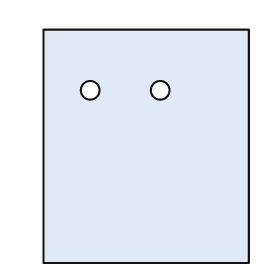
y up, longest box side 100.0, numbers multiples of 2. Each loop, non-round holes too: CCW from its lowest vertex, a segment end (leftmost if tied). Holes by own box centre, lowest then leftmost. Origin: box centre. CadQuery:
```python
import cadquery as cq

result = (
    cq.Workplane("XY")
    .moveTo(-44.0, -50.0)
    .lineTo(44.0, -50.0)
    .lineTo(44.0, 50.0)
    .lineTo(-44.0, 50.0)
    .close()
    .moveTo(-24.0, 24.0)
    .circle(4.0)
    .moveTo(6.0, 24.0)
    .circle(4.0)
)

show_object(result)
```